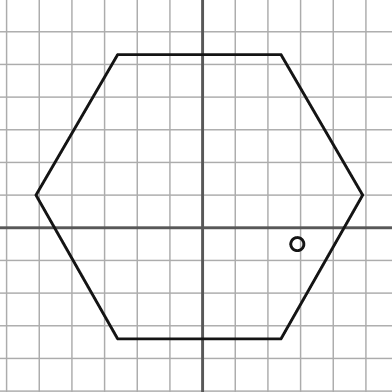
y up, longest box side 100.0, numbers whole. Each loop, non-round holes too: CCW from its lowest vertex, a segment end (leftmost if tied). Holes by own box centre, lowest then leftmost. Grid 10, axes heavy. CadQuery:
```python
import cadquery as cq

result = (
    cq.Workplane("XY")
    .moveTo(-26.0, -34.0)
    .lineTo(24.0, -34.0)
    .lineTo(49.0, 10.0)
    .lineTo(24.0, 53.0)
    .lineTo(-26.0, 53.0)
    .lineTo(-51.0, 10.0)
    .close()
    .moveTo(29.0, -5.0)
    .circle(2.0)
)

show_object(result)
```